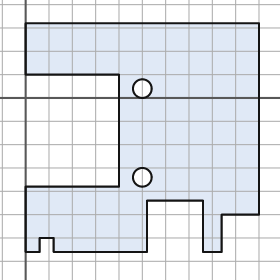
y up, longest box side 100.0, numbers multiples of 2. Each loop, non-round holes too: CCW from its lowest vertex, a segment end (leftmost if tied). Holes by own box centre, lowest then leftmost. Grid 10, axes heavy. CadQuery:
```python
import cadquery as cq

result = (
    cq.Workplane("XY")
    .moveTo(0.0, -66.0)
    .lineTo(6.0, -66.0)
    .lineTo(6.0, -60.0)
    .lineTo(12.0, -60.0)
    .lineTo(12.0, -66.0)
    .lineTo(52.0, -66.0)
    .lineTo(52.0, -44.0)
    .lineTo(76.0, -44.0)
    .lineTo(76.0, -66.0)
    .lineTo(84.0, -66.0)
    .lineTo(84.0, -50.0)
    .lineTo(100.0, -50.0)
    .lineTo(100.0, 32.0)
    .lineTo(0.0, 32.0)
    .lineTo(0.0, 10.0)
    .lineTo(40.0, 10.0)
    .lineTo(40.0, -38.0)
    .lineTo(0.0, -38.0)
    .close()
    .moveTo(50.0, -34.0)
    .circle(4.0)
    .moveTo(50.0, 4.0)
    .circle(4.0)
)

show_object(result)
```